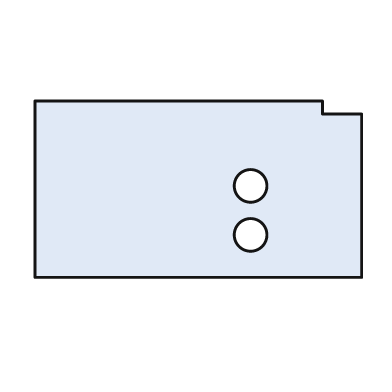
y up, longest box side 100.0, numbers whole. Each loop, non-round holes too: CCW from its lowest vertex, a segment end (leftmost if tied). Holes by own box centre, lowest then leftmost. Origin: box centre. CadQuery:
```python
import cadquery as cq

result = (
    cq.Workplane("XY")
    .moveTo(-50.0, -27.0)
    .lineTo(50.0, -27.0)
    .lineTo(50.0, 23.0)
    .lineTo(38.0, 23.0)
    .lineTo(38.0, 27.0)
    .lineTo(-50.0, 27.0)
    .close()
    .moveTo(16.0, -14.0)
    .circle(5.0)
    .moveTo(16.0, 1.0)
    .circle(5.0)
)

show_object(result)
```